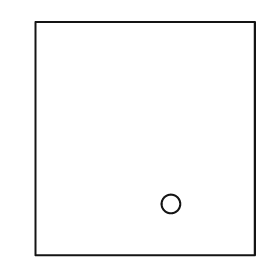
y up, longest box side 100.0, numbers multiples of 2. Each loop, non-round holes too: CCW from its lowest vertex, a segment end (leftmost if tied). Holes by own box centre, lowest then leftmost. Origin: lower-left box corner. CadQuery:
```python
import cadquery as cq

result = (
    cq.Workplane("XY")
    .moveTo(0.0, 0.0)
    .lineTo(94.0, 0.0)
    .lineTo(94.0, 100.0)
    .lineTo(0.0, 100.0)
    .close()
    .moveTo(58.0, 22.0)
    .circle(4.0)
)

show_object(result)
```